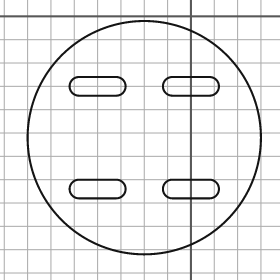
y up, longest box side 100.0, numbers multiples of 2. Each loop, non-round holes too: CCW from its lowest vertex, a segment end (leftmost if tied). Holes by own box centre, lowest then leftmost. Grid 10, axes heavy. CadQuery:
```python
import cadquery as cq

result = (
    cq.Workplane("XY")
    .moveTo(-20.0, -52.0)
    .circle(50.0)
    .moveTo(-48.0, -78.0)
    .lineTo(-32.0, -78.0)
    .threePointArc((-28.0, -74.0), (-32.0, -70.0))
    .lineTo(-48.0, -70.0)
    .threePointArc((-52.0, -74.0), (-48.0, -78.0))
    .close()
    .moveTo(-8.0, -78.0)
    .lineTo(8.0, -78.0)
    .threePointArc((12.0, -74.0), (8.0, -70.0))
    .lineTo(-8.0, -70.0)
    .threePointArc((-12.0, -74.0), (-8.0, -78.0))
    .close()
    .moveTo(-48.0, -34.0)
    .lineTo(-32.0, -34.0)
    .threePointArc((-28.0, -30.0), (-32.0, -26.0))
    .lineTo(-48.0, -26.0)
    .threePointArc((-52.0, -30.0), (-48.0, -34.0))
    .close()
    .moveTo(-8.0, -34.0)
    .lineTo(8.0, -34.0)
    .threePointArc((12.0, -30.0), (8.0, -26.0))
    .lineTo(-8.0, -26.0)
    .threePointArc((-12.0, -30.0), (-8.0, -34.0))
    .close()
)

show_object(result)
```